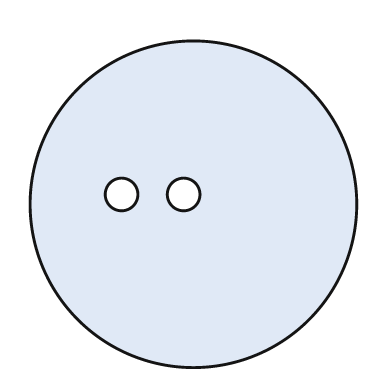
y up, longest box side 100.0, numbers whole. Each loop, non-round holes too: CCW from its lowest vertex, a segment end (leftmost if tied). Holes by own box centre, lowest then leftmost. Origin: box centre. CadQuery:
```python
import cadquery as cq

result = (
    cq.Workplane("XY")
    .moveTo(0.0, 0.0)
    .circle(50.0)
    .moveTo(-22.0, 3.0)
    .circle(5.0)
    .moveTo(-3.0, 3.0)
    .circle(5.0)
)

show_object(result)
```